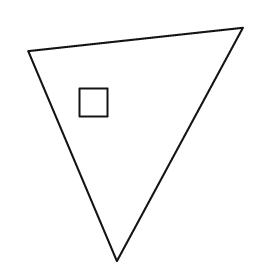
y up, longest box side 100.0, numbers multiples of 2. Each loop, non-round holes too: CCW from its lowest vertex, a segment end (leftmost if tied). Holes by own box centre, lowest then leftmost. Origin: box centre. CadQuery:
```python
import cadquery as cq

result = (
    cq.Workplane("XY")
    .moveTo(-8.0, -50.0)
    .lineTo(46.0, 50.0)
    .lineTo(-46.0, 40.0)
    .close()
    .moveTo(-24.0, 12.0)
    .lineTo(-12.0, 12.0)
    .lineTo(-12.0, 24.0)
    .lineTo(-24.0, 24.0)
    .close()
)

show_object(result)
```